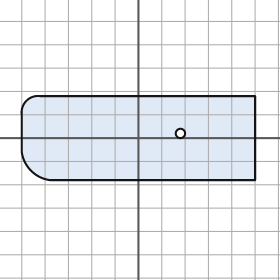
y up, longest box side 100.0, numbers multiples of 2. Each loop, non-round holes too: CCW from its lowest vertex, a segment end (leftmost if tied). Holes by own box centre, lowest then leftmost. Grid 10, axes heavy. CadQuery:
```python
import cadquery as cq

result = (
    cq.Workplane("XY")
    .moveTo(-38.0, -18.0)
    .lineTo(50.0, -18.0)
    .lineTo(50.0, 18.0)
    .lineTo(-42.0, 18.0)
    .threePointArc((-48.0, 16.0), (-50.0, 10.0))
    .lineTo(-50.0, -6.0)
    .threePointArc((-46.0, -14.0), (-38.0, -18.0))
    .close()
    .moveTo(18.0, 2.0)
    .circle(2.0)
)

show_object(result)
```